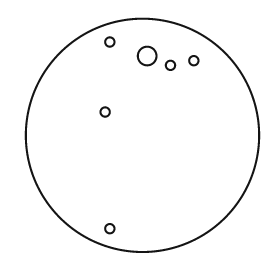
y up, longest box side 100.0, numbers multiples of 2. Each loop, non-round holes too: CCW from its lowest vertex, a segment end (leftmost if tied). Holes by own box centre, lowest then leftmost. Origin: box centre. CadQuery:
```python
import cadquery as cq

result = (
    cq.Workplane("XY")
    .moveTo(0.0, 0.0)
    .circle(50.0)
    .moveTo(-14.0, -40.0)
    .circle(2.0)
    .moveTo(-16.0, 10.0)
    .circle(2.0)
    .moveTo(12.0, 30.0)
    .circle(2.0)
    .moveTo(22.0, 32.0)
    .circle(2.0)
    .moveTo(2.0, 34.0)
    .circle(4.0)
    .moveTo(-14.0, 40.0)
    .circle(2.0)
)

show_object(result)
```